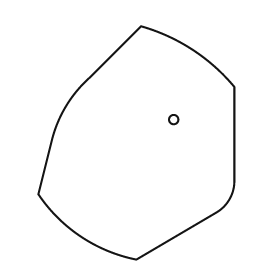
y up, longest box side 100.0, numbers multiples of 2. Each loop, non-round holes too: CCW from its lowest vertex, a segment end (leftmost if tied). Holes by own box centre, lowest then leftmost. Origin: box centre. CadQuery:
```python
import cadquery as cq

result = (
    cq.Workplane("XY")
    .moveTo(0.0, -50.0)
    .lineTo(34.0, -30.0)
    .threePointArc((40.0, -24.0), (42.0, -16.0))
    .lineTo(42.0, 24.0)
    .threePointArc((24.0, 40.0), (2.0, 50.0))
    .lineTo(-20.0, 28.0)
    .threePointArc((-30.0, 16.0), (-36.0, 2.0))
    .lineTo(-42.0, -22.0)
    .threePointArc((-24.0, -40.0), (0.0, -50.0))
    .close()
    .moveTo(16.0, 10.0)
    .circle(2.0)
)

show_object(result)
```